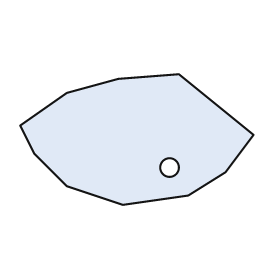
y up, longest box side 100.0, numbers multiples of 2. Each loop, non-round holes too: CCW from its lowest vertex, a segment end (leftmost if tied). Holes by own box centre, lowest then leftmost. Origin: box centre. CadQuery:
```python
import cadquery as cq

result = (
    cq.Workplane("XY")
    .moveTo(-6.0, -28.0)
    .lineTo(22.0, -24.0)
    .lineTo(38.0, -14.0)
    .lineTo(50.0, 2.0)
    .lineTo(18.0, 28.0)
    .lineTo(-8.0, 26.0)
    .lineTo(-30.0, 20.0)
    .lineTo(-50.0, 6.0)
    .lineTo(-44.0, -6.0)
    .lineTo(-30.0, -20.0)
    .close()
    .moveTo(14.0, -12.0)
    .circle(4.0)
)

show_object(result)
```